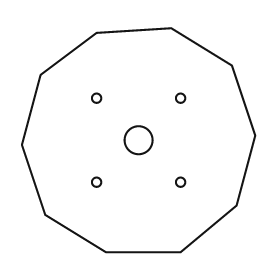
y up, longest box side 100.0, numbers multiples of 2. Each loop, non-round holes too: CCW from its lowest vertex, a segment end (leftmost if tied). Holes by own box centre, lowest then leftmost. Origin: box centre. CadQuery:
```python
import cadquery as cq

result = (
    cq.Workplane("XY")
    .moveTo(-14.0, -48.0)
    .lineTo(18.0, -48.0)
    .lineTo(42.0, -28.0)
    .lineTo(50.0, 2.0)
    .lineTo(40.0, 32.0)
    .lineTo(14.0, 48.0)
    .lineTo(-18.0, 46.0)
    .lineTo(-42.0, 28.0)
    .lineTo(-50.0, -2.0)
    .lineTo(-40.0, -32.0)
    .close()
    .moveTo(-18.0, -18.0)
    .circle(2.0)
    .moveTo(18.0, -18.0)
    .circle(2.0)
    .moveTo(0.0, 0.0)
    .circle(6.0)
    .moveTo(-18.0, 18.0)
    .circle(2.0)
    .moveTo(18.0, 18.0)
    .circle(2.0)
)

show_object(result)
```